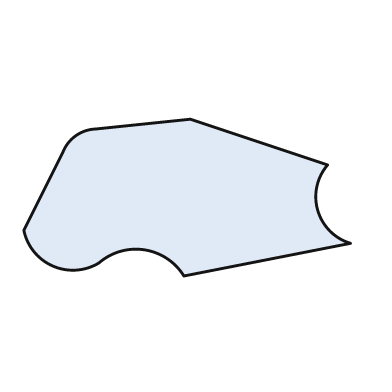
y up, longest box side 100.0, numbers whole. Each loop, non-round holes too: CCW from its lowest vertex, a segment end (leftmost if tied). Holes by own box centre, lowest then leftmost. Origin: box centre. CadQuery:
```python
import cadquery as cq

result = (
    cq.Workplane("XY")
    .moveTo(-1.0, -24.0)
    .lineTo(50.0, -14.0)
    .threePointArc((40.0, -4.0), (43.0, 10.0))
    .lineTo(1.0, 24.0)
    .lineTo(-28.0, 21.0)
    .threePointArc((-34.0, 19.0), (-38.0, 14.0))
    .lineTo(-50.0, -10.0)
    .threePointArc((-41.0, -21.0), (-27.0, -20.0))
    .threePointArc((-13.0, -16.0), (-1.0, -24.0))
    .close()
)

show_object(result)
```